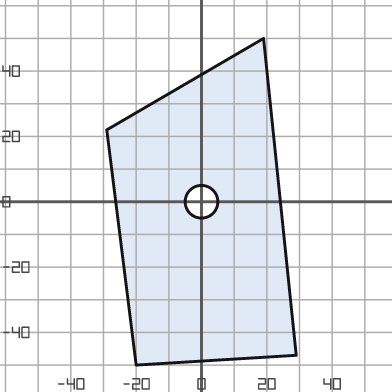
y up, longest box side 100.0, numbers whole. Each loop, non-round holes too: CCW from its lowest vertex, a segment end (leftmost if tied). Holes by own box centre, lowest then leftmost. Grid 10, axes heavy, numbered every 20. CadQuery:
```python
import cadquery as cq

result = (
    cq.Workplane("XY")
    .moveTo(-20.0, -50.0)
    .lineTo(29.0, -47.0)
    .lineTo(19.0, 50.0)
    .lineTo(-29.0, 22.0)
    .close()
    .moveTo(0.0, 0.0)
    .circle(5.0)
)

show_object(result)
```